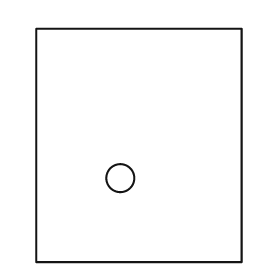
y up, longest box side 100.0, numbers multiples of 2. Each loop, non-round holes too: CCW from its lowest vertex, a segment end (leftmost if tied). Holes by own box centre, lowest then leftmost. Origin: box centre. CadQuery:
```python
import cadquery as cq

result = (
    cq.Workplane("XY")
    .moveTo(-44.0, -50.0)
    .lineTo(44.0, -50.0)
    .lineTo(44.0, 50.0)
    .lineTo(-44.0, 50.0)
    .close()
    .moveTo(-8.0, -14.0)
    .circle(6.0)
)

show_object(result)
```